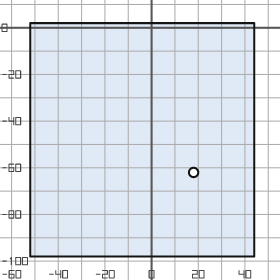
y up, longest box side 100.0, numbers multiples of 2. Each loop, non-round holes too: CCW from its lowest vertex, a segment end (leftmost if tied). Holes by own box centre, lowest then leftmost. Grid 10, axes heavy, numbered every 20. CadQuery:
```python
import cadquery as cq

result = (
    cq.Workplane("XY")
    .moveTo(-52.0, -98.0)
    .lineTo(44.0, -98.0)
    .lineTo(44.0, 2.0)
    .lineTo(-52.0, 2.0)
    .close()
    .moveTo(18.0, -62.0)
    .circle(2.0)
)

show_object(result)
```